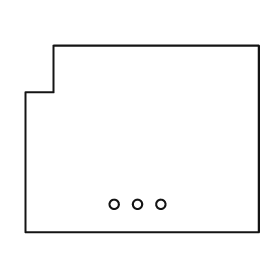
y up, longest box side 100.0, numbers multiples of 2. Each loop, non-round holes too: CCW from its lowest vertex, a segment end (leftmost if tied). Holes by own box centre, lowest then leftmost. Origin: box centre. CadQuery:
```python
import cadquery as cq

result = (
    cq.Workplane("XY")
    .moveTo(-50.0, -40.0)
    .lineTo(50.0, -40.0)
    .lineTo(50.0, 40.0)
    .lineTo(-38.0, 40.0)
    .lineTo(-38.0, 20.0)
    .lineTo(-50.0, 20.0)
    .close()
    .moveTo(-12.0, -28.0)
    .circle(2.0)
    .moveTo(-2.0, -28.0)
    .circle(2.0)
    .moveTo(8.0, -28.0)
    .circle(2.0)
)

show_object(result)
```